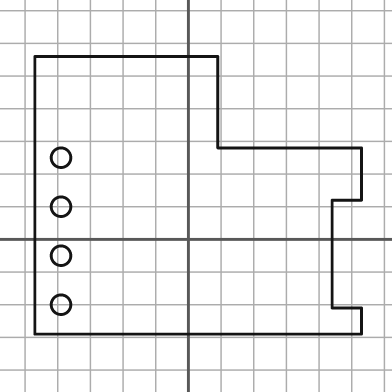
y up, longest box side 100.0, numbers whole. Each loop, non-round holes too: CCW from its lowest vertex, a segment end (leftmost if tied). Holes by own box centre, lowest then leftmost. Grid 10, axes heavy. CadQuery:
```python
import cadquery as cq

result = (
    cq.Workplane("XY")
    .moveTo(-47.0, -29.0)
    .lineTo(53.0, -29.0)
    .lineTo(53.0, -21.0)
    .lineTo(44.0, -21.0)
    .lineTo(44.0, 12.0)
    .lineTo(53.0, 12.0)
    .lineTo(53.0, 28.0)
    .lineTo(9.0, 28.0)
    .lineTo(9.0, 56.0)
    .lineTo(-47.0, 56.0)
    .close()
    .moveTo(-39.0, -20.0)
    .circle(3.0)
    .moveTo(-39.0, -5.0)
    .circle(3.0)
    .moveTo(-39.0, 10.0)
    .circle(3.0)
    .moveTo(-39.0, 25.0)
    .circle(3.0)
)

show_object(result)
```